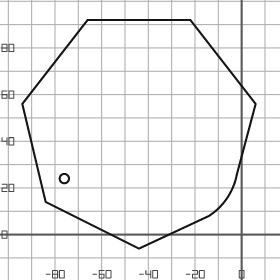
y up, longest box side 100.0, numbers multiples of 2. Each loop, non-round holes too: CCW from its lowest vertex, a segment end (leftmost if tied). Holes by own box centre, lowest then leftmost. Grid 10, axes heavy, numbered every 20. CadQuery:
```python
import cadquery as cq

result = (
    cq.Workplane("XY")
    .moveTo(-44.0, -6.0)
    .lineTo(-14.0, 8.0)
    .threePointArc((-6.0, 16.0), (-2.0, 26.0))
    .lineTo(6.0, 56.0)
    .lineTo(-22.0, 92.0)
    .lineTo(-66.0, 92.0)
    .lineTo(-94.0, 56.0)
    .lineTo(-84.0, 14.0)
    .close()
    .moveTo(-76.0, 24.0)
    .circle(2.0)
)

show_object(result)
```